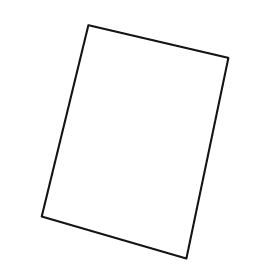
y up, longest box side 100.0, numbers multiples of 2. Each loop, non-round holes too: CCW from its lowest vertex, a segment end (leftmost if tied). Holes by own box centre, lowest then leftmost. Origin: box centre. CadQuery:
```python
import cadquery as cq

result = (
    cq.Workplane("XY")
    .moveTo(22.0, -50.0)
    .lineTo(40.0, 36.0)
    .lineTo(-20.0, 50.0)
    .lineTo(-40.0, -32.0)
    .close()
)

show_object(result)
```